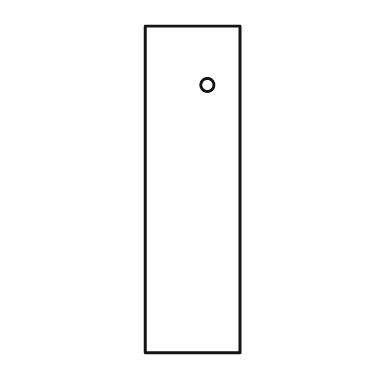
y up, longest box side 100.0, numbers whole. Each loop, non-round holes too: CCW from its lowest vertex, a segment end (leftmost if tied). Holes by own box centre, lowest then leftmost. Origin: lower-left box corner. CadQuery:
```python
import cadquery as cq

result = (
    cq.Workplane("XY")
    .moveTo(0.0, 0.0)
    .lineTo(29.0, 0.0)
    .lineTo(29.0, 100.0)
    .lineTo(0.0, 100.0)
    .close()
    .moveTo(19.0, 82.0)
    .circle(2.0)
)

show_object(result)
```